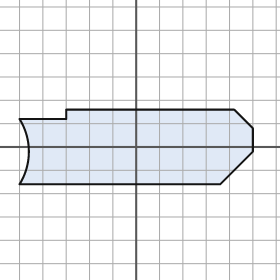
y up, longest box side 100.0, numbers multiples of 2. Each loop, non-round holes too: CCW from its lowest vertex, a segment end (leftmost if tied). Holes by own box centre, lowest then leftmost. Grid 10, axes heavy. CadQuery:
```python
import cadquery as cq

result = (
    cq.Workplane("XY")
    .moveTo(-50.0, -16.0)
    .lineTo(36.0, -16.0)
    .lineTo(50.0, -2.0)
    .lineTo(50.0, 8.0)
    .lineTo(42.0, 16.0)
    .lineTo(-30.0, 16.0)
    .lineTo(-30.0, 12.0)
    .lineTo(-50.0, 12.0)
    .threePointArc((-46.0, -2.0), (-50.0, -16.0))
    .close()
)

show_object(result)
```